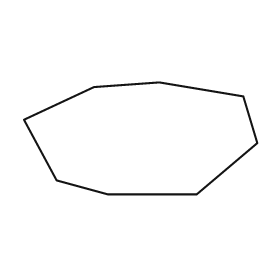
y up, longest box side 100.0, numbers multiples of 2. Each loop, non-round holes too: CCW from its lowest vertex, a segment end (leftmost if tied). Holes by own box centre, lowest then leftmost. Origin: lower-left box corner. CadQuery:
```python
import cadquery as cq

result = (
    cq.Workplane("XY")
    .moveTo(36.0, 0.0)
    .lineTo(74.0, 0.0)
    .lineTo(100.0, 22.0)
    .lineTo(94.0, 42.0)
    .lineTo(58.0, 48.0)
    .lineTo(30.0, 46.0)
    .lineTo(0.0, 32.0)
    .lineTo(14.0, 6.0)
    .close()
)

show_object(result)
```